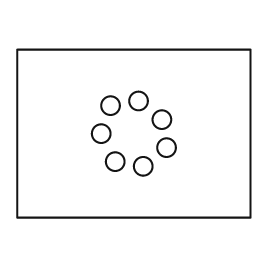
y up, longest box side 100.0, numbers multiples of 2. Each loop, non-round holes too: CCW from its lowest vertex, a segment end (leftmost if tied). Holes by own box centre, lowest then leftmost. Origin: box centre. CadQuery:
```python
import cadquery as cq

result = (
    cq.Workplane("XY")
    .moveTo(-50.0, -36.0)
    .lineTo(50.0, -36.0)
    .lineTo(50.0, 36.0)
    .lineTo(-50.0, 36.0)
    .close()
    .moveTo(4.0, -14.0)
    .circle(4.0)
    .moveTo(-8.0, -12.0)
    .circle(4.0)
    .moveTo(14.0, -6.0)
    .circle(4.0)
    .moveTo(-14.0, 0.0)
    .circle(4.0)
    .moveTo(12.0, 6.0)
    .circle(4.0)
    .moveTo(-10.0, 12.0)
    .circle(4.0)
    .moveTo(2.0, 14.0)
    .circle(4.0)
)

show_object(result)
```